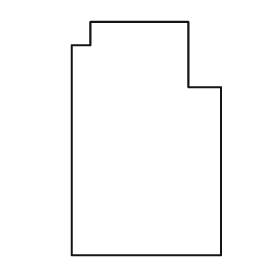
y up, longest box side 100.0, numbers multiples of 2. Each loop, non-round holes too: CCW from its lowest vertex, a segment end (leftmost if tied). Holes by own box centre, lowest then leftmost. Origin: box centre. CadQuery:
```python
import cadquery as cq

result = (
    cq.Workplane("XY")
    .moveTo(-32.0, -50.0)
    .lineTo(32.0, -50.0)
    .lineTo(32.0, 22.0)
    .lineTo(18.0, 22.0)
    .lineTo(18.0, 50.0)
    .lineTo(-24.0, 50.0)
    .lineTo(-24.0, 40.0)
    .lineTo(-32.0, 40.0)
    .close()
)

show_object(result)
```